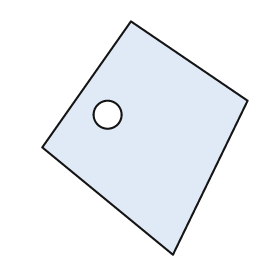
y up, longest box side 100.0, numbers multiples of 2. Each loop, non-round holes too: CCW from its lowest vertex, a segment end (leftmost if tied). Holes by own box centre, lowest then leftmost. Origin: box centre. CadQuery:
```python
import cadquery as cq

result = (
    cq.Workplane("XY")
    .moveTo(12.0, -50.0)
    .lineTo(44.0, 16.0)
    .lineTo(-6.0, 50.0)
    .lineTo(-44.0, -4.0)
    .close()
    .moveTo(-16.0, 10.0)
    .circle(6.0)
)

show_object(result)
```